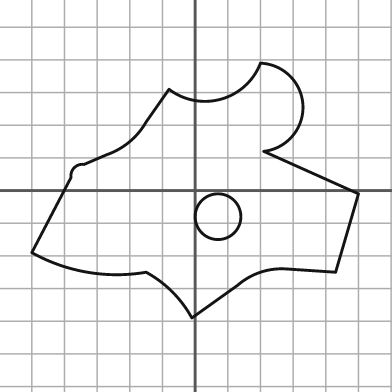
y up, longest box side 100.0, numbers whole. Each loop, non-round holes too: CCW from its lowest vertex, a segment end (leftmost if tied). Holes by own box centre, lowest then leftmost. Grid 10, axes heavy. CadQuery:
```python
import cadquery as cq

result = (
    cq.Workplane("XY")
    .moveTo(-1.0, -39.0)
    .lineTo(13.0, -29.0)
    .threePointArc((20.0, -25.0), (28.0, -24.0))
    .lineTo(43.0, -25.0)
    .lineTo(50.0, -1.0)
    .lineTo(21.0, 12.0)
    .threePointArc((33.0, 26.0), (20.0, 39.0))
    .threePointArc((8.0, 28.0), (-8.0, 31.0))
    .lineTo(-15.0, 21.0)
    .threePointArc((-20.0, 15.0), (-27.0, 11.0))
    .lineTo(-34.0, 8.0)
    .threePointArc((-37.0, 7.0), (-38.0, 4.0))
    .lineTo(-50.0, -19.0)
    .threePointArc((-33.0, -25.0), (-15.0, -25.0))
    .threePointArc((-7.0, -31.0), (-1.0, -39.0))
    .close()
    .moveTo(7.0, -8.0)
    .circle(7.0)
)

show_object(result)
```